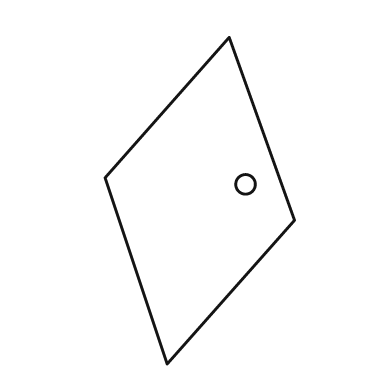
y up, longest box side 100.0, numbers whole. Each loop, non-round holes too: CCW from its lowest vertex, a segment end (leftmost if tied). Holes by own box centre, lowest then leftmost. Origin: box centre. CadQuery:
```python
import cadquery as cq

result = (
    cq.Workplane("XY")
    .moveTo(-10.0, -50.0)
    .lineTo(29.0, -6.0)
    .lineTo(9.0, 50.0)
    .lineTo(-29.0, 7.0)
    .close()
    .moveTo(14.0, 5.0)
    .circle(3.0)
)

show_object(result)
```